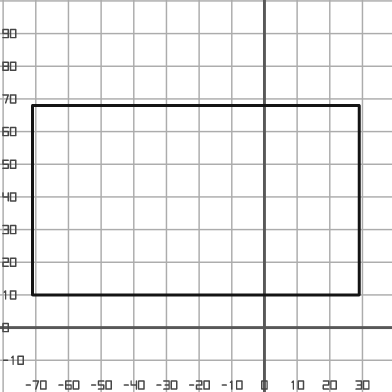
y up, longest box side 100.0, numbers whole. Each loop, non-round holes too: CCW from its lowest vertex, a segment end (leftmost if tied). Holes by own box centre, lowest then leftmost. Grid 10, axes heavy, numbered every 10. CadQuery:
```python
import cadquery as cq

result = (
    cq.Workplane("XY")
    .moveTo(-71.0, 10.0)
    .lineTo(29.0, 10.0)
    .lineTo(29.0, 68.0)
    .lineTo(-71.0, 68.0)
    .close()
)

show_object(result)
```